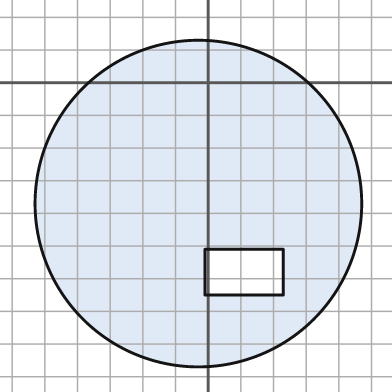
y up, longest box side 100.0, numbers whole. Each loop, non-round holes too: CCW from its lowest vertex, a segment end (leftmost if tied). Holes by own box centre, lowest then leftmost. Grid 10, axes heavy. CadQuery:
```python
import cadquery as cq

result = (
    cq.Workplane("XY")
    .moveTo(-3.0, -37.0)
    .circle(50.0)
    .moveTo(-1.0, -65.0)
    .lineTo(23.0, -65.0)
    .lineTo(23.0, -51.0)
    .lineTo(-1.0, -51.0)
    .close()
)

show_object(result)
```